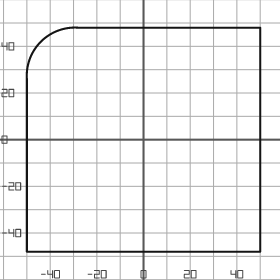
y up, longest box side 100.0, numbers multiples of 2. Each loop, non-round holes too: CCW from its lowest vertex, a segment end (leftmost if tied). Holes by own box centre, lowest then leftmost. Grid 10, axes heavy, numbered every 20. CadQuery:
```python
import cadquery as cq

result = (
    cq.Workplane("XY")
    .moveTo(-50.0, -48.0)
    .lineTo(50.0, -48.0)
    .lineTo(50.0, 48.0)
    .lineTo(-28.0, 48.0)
    .threePointArc((-44.0, 42.0), (-50.0, 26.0))
    .close()
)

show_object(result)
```